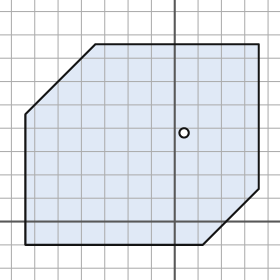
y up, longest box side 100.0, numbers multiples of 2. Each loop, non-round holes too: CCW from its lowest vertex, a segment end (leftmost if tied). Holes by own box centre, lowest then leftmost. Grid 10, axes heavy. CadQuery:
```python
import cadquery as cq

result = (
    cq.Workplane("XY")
    .moveTo(-64.0, -10.0)
    .lineTo(12.0, -10.0)
    .lineTo(36.0, 14.0)
    .lineTo(36.0, 76.0)
    .lineTo(-34.0, 76.0)
    .lineTo(-64.0, 46.0)
    .close()
    .moveTo(4.0, 38.0)
    .circle(2.0)
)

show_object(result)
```